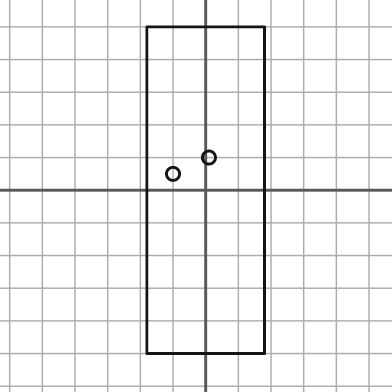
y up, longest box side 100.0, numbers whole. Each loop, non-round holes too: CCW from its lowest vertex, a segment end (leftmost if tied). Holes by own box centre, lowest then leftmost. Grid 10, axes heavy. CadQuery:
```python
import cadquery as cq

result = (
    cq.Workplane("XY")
    .moveTo(-18.0, -50.0)
    .lineTo(18.0, -50.0)
    .lineTo(18.0, 50.0)
    .lineTo(-18.0, 50.0)
    .close()
    .moveTo(-10.0, 5.0)
    .circle(2.0)
    .moveTo(1.0, 10.0)
    .circle(2.0)
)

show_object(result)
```